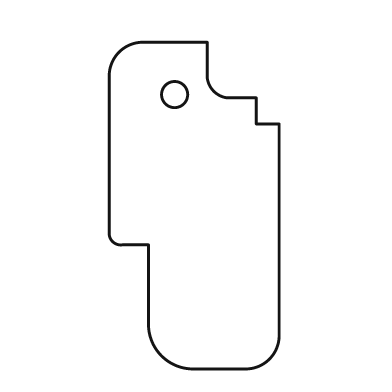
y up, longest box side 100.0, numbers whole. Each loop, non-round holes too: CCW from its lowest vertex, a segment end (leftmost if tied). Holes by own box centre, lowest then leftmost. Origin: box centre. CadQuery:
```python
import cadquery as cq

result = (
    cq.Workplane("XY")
    .moveTo(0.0, -50.0)
    .lineTo(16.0, -50.0)
    .threePointArc((23.0, -47.0), (26.0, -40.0))
    .lineTo(26.0, 25.0)
    .lineTo(19.0, 25.0)
    .lineTo(19.0, 33.0)
    .lineTo(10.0, 33.0)
    .threePointArc((6.0, 35.0), (4.0, 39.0))
    .lineTo(4.0, 50.0)
    .lineTo(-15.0, 50.0)
    .threePointArc((-23.0, 47.0), (-26.0, 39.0))
    .lineTo(-26.0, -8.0)
    .threePointArc((-25.0, -11.0), (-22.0, -12.0))
    .lineTo(-14.0, -12.0)
    .lineTo(-14.0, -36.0)
    .threePointArc((-10.0, -46.0), (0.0, -50.0))
    .close()
    .moveTo(-6.0, 34.0)
    .circle(4.0)
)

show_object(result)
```